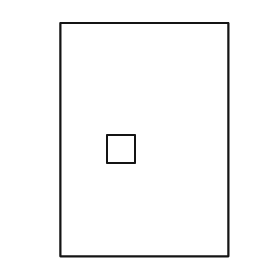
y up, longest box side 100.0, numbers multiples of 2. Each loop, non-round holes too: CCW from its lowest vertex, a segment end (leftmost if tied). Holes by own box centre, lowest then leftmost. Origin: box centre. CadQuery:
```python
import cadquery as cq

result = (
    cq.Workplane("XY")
    .moveTo(-36.0, -50.0)
    .lineTo(36.0, -50.0)
    .lineTo(36.0, 50.0)
    .lineTo(-36.0, 50.0)
    .close()
    .moveTo(-16.0, -10.0)
    .lineTo(-4.0, -10.0)
    .lineTo(-4.0, 2.0)
    .lineTo(-16.0, 2.0)
    .close()
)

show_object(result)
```